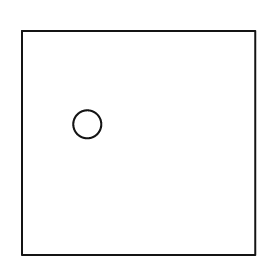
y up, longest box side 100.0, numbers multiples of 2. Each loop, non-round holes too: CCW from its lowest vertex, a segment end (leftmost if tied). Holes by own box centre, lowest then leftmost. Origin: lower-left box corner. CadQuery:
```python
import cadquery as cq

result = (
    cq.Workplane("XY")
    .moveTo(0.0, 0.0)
    .lineTo(100.0, 0.0)
    .lineTo(100.0, 96.0)
    .lineTo(0.0, 96.0)
    .close()
    .moveTo(28.0, 56.0)
    .circle(6.0)
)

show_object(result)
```